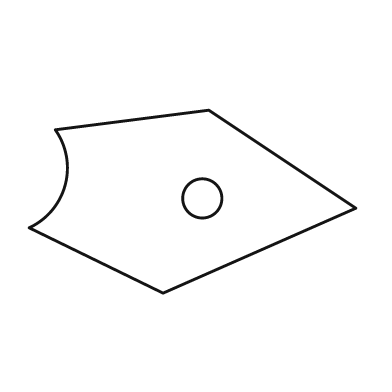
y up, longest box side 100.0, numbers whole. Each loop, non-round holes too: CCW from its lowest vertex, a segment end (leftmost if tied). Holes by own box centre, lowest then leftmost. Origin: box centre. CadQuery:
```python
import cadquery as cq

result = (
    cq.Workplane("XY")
    .moveTo(-9.0, -28.0)
    .lineTo(50.0, -2.0)
    .lineTo(5.0, 28.0)
    .lineTo(-42.0, 22.0)
    .threePointArc((-39.0, 5.0), (-50.0, -8.0))
    .close()
    .moveTo(3.0, 1.0)
    .circle(6.0)
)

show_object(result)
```